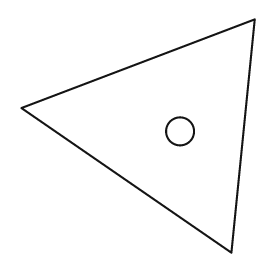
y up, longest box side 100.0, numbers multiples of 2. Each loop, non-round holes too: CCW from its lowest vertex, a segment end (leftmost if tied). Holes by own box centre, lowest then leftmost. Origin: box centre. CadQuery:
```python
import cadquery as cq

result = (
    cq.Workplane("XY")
    .moveTo(40.0, -50.0)
    .lineTo(50.0, 50.0)
    .lineTo(-50.0, 12.0)
    .close()
    .moveTo(18.0, 2.0)
    .circle(6.0)
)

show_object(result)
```